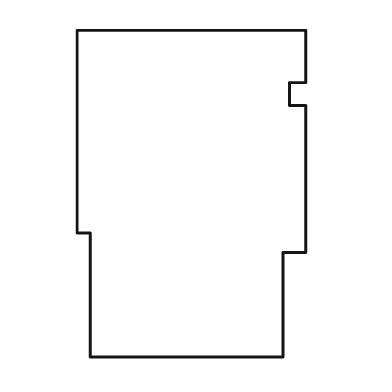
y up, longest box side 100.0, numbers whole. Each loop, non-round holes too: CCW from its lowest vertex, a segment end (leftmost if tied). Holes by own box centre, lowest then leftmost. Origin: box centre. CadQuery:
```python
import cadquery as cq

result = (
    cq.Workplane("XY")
    .moveTo(-31.0, -50.0)
    .lineTo(28.0, -50.0)
    .lineTo(28.0, -18.0)
    .lineTo(35.0, -18.0)
    .lineTo(35.0, 27.0)
    .lineTo(30.0, 27.0)
    .lineTo(30.0, 34.0)
    .lineTo(35.0, 34.0)
    .lineTo(35.0, 50.0)
    .lineTo(-35.0, 50.0)
    .lineTo(-35.0, -12.0)
    .lineTo(-31.0, -12.0)
    .close()
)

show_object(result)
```